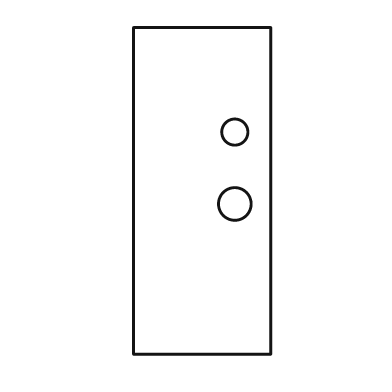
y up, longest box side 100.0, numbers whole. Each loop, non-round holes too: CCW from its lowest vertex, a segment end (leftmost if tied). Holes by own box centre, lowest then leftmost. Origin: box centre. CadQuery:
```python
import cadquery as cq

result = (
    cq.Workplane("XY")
    .moveTo(-21.0, -50.0)
    .lineTo(21.0, -50.0)
    .lineTo(21.0, 50.0)
    .lineTo(-21.0, 50.0)
    .close()
    .moveTo(10.0, -4.0)
    .circle(5.0)
    .moveTo(10.0, 18.0)
    .circle(4.0)
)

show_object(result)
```